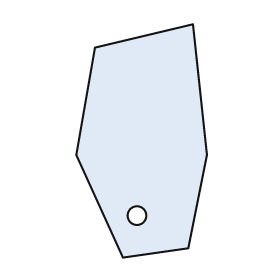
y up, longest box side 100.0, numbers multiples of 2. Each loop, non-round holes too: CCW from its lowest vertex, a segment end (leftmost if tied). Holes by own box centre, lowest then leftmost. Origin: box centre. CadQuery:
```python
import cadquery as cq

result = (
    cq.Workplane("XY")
    .moveTo(-8.0, -50.0)
    .lineTo(20.0, -46.0)
    .lineTo(28.0, -6.0)
    .lineTo(22.0, 50.0)
    .lineTo(-20.0, 40.0)
    .lineTo(-28.0, -6.0)
    .close()
    .moveTo(-2.0, -32.0)
    .circle(4.0)
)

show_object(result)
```